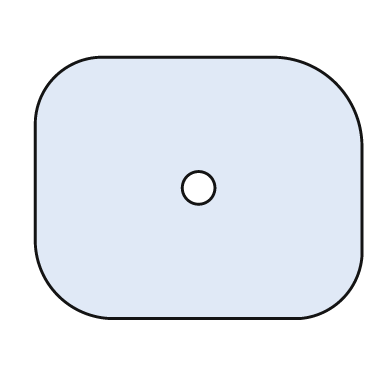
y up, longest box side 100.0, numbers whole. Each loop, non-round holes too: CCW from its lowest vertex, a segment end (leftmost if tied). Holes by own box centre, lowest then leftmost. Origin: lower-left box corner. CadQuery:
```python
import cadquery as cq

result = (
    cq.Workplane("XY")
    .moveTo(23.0, 0.0)
    .lineTo(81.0, 0.0)
    .threePointArc((94.0, 6.0), (100.0, 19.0))
    .lineTo(100.0, 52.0)
    .threePointArc((92.0, 72.0), (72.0, 80.0))
    .lineTo(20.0, 80.0)
    .threePointArc((6.0, 74.0), (0.0, 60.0))
    .lineTo(0.0, 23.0)
    .threePointArc((7.0, 7.0), (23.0, 0.0))
    .close()
    .moveTo(50.0, 40.0)
    .circle(5.0)
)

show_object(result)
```